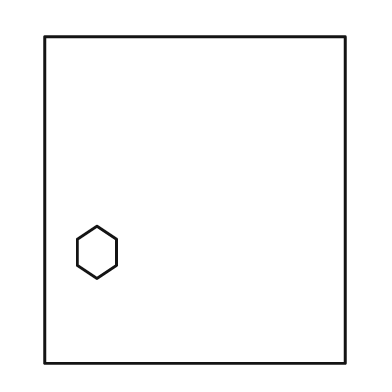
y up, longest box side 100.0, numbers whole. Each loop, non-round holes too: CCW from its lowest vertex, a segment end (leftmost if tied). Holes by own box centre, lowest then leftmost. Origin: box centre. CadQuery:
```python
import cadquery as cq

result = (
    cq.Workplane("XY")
    .moveTo(-46.0, -50.0)
    .lineTo(46.0, -50.0)
    .lineTo(46.0, 50.0)
    .lineTo(-46.0, 50.0)
    .close()
    .moveTo(-30.0, -24.0)
    .lineTo(-24.0, -20.0)
    .lineTo(-24.0, -12.0)
    .lineTo(-30.0, -8.0)
    .lineTo(-36.0, -12.0)
    .lineTo(-36.0, -20.0)
    .close()
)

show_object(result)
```